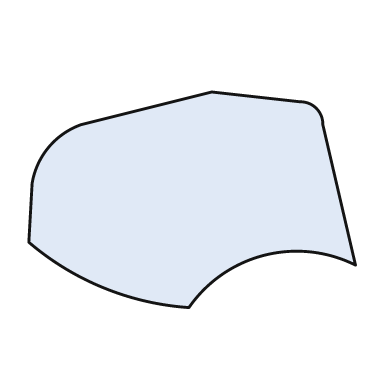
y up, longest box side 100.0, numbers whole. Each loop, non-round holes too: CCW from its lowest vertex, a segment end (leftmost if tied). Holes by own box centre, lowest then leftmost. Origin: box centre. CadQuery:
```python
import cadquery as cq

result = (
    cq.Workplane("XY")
    .moveTo(-1.0, -33.0)
    .threePointArc((22.0, -17.0), (50.0, -20.0))
    .lineTo(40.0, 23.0)
    .threePointArc((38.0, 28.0), (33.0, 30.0))
    .lineTo(6.0, 33.0)
    .lineTo(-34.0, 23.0)
    .threePointArc((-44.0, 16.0), (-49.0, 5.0))
    .lineTo(-50.0, -13.0)
    .threePointArc((-27.0, -27.0), (-1.0, -33.0))
    .close()
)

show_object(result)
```